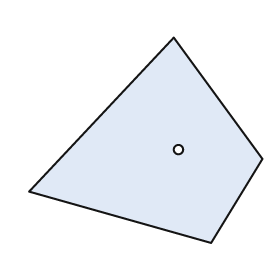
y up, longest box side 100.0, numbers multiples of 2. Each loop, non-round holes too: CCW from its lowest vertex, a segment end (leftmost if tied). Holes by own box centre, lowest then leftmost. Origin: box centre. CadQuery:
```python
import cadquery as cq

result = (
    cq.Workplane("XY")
    .moveTo(28.0, -44.0)
    .lineTo(50.0, -8.0)
    .lineTo(12.0, 44.0)
    .lineTo(-50.0, -22.0)
    .close()
    .moveTo(14.0, -4.0)
    .circle(2.0)
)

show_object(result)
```